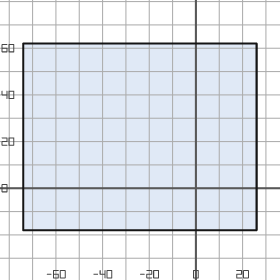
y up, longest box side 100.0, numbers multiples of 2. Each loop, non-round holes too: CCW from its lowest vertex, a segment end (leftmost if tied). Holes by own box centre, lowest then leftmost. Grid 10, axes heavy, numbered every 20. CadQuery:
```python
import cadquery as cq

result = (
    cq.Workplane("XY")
    .moveTo(-74.0, -18.0)
    .lineTo(26.0, -18.0)
    .lineTo(26.0, 62.0)
    .lineTo(-74.0, 62.0)
    .close()
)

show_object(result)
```